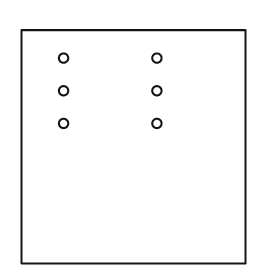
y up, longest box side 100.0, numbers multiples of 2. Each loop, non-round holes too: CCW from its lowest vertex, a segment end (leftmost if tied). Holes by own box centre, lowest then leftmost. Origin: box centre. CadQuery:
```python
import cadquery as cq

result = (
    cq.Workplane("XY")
    .moveTo(-48.0, -50.0)
    .lineTo(48.0, -50.0)
    .lineTo(48.0, 50.0)
    .lineTo(-48.0, 50.0)
    .close()
    .moveTo(-30.0, 10.0)
    .circle(2.0)
    .moveTo(10.0, 10.0)
    .circle(2.0)
    .moveTo(-30.0, 24.0)
    .circle(2.0)
    .moveTo(10.0, 24.0)
    .circle(2.0)
    .moveTo(-30.0, 38.0)
    .circle(2.0)
    .moveTo(10.0, 38.0)
    .circle(2.0)
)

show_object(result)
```